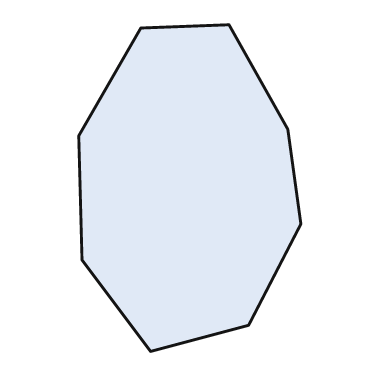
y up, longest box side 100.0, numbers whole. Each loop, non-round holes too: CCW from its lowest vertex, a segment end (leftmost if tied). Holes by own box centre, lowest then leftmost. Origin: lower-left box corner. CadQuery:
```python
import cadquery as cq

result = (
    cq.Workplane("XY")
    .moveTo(22.0, 0.0)
    .lineTo(52.0, 8.0)
    .lineTo(68.0, 39.0)
    .lineTo(64.0, 68.0)
    .lineTo(46.0, 100.0)
    .lineTo(19.0, 99.0)
    .lineTo(0.0, 66.0)
    .lineTo(1.0, 28.0)
    .close()
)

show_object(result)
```